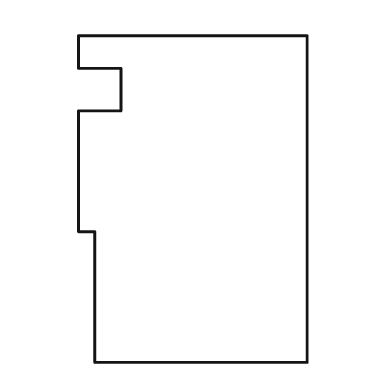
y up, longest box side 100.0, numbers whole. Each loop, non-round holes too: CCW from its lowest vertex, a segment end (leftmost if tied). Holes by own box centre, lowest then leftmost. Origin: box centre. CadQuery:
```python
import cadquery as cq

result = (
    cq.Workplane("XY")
    .moveTo(-30.0, -50.0)
    .lineTo(35.0, -50.0)
    .lineTo(35.0, 50.0)
    .lineTo(-35.0, 50.0)
    .lineTo(-35.0, 40.0)
    .lineTo(-22.0, 40.0)
    .lineTo(-22.0, 27.0)
    .lineTo(-35.0, 27.0)
    .lineTo(-35.0, -10.0)
    .lineTo(-30.0, -10.0)
    .close()
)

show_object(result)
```